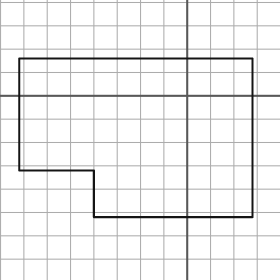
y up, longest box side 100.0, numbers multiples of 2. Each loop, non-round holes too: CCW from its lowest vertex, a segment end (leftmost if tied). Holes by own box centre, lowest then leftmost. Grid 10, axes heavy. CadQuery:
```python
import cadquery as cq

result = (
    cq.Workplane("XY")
    .moveTo(-40.0, -52.0)
    .lineTo(28.0, -52.0)
    .lineTo(28.0, 16.0)
    .lineTo(-72.0, 16.0)
    .lineTo(-72.0, -32.0)
    .lineTo(-40.0, -32.0)
    .close()
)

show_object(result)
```